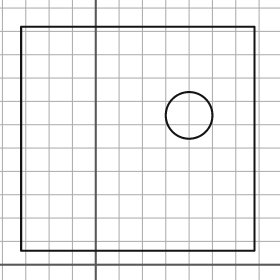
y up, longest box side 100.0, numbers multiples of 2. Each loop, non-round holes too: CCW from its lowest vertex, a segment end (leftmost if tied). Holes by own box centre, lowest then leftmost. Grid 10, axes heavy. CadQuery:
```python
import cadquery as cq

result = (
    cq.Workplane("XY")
    .moveTo(-32.0, 6.0)
    .lineTo(68.0, 6.0)
    .lineTo(68.0, 102.0)
    .lineTo(-32.0, 102.0)
    .close()
    .moveTo(40.0, 64.0)
    .circle(10.0)
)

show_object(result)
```